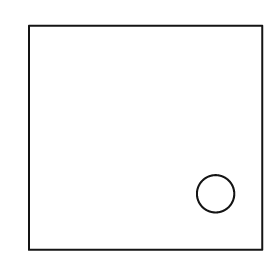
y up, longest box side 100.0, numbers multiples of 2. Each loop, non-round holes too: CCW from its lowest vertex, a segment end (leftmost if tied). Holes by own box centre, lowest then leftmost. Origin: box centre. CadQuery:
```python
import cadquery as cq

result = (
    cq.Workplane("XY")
    .moveTo(-50.0, -48.0)
    .lineTo(50.0, -48.0)
    .lineTo(50.0, 48.0)
    .lineTo(-50.0, 48.0)
    .close()
    .moveTo(30.0, -24.0)
    .circle(8.0)
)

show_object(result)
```